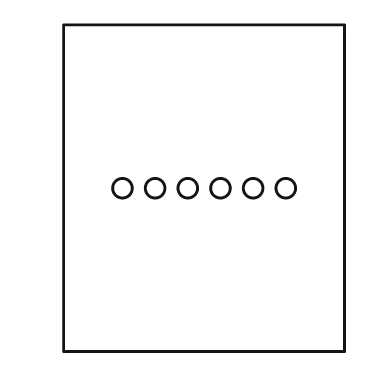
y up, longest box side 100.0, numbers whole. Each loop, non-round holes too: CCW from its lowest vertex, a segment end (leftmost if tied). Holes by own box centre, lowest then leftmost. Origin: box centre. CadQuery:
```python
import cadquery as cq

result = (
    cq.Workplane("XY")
    .moveTo(-43.0, -50.0)
    .lineTo(43.0, -50.0)
    .lineTo(43.0, 50.0)
    .lineTo(-43.0, 50.0)
    .close()
    .moveTo(-25.0, 0.0)
    .circle(3.0)
    .moveTo(-15.0, 0.0)
    .circle(3.0)
    .moveTo(-5.0, 0.0)
    .circle(3.0)
    .moveTo(5.0, 0.0)
    .circle(3.0)
    .moveTo(15.0, 0.0)
    .circle(3.0)
    .moveTo(25.0, 0.0)
    .circle(3.0)
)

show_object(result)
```